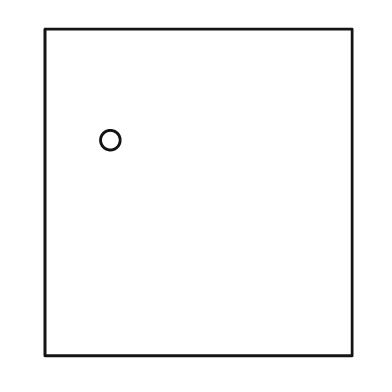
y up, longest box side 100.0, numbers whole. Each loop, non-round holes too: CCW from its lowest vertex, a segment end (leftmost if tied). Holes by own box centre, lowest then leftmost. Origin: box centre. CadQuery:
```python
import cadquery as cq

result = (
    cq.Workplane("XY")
    .moveTo(-47.0, -50.0)
    .lineTo(47.0, -50.0)
    .lineTo(47.0, 50.0)
    .lineTo(-47.0, 50.0)
    .close()
    .moveTo(-27.0, 16.0)
    .circle(3.0)
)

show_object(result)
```